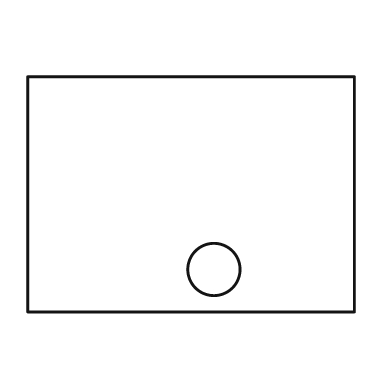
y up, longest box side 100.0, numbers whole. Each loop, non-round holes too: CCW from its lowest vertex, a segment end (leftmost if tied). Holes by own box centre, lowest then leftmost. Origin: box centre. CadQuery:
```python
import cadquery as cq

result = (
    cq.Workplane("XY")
    .moveTo(-50.0, -36.0)
    .lineTo(50.0, -36.0)
    .lineTo(50.0, 36.0)
    .lineTo(-50.0, 36.0)
    .close()
    .moveTo(7.0, -23.0)
    .circle(8.0)
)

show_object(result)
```